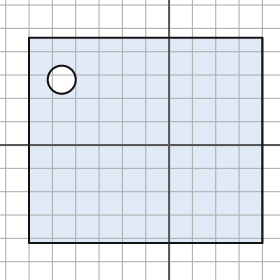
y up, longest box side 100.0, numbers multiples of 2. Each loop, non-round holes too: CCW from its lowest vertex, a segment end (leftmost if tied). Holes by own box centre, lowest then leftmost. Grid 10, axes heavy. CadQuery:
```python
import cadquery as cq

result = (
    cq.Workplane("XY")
    .moveTo(-60.0, -42.0)
    .lineTo(40.0, -42.0)
    .lineTo(40.0, 46.0)
    .lineTo(-60.0, 46.0)
    .close()
    .moveTo(-46.0, 28.0)
    .circle(6.0)
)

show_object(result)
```